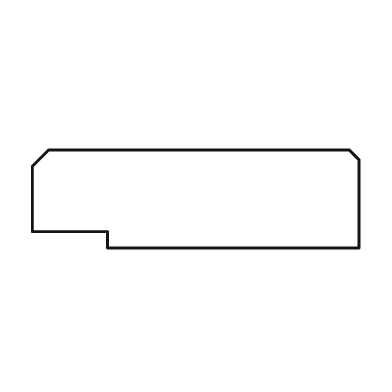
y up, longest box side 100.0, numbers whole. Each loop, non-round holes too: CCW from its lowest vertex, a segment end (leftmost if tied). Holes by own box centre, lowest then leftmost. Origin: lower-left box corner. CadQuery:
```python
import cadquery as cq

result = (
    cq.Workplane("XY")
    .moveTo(23.0, 0.0)
    .lineTo(100.0, 0.0)
    .lineTo(100.0, 27.0)
    .lineTo(97.0, 30.0)
    .lineTo(5.0, 30.0)
    .lineTo(0.0, 25.0)
    .lineTo(0.0, 5.0)
    .lineTo(23.0, 5.0)
    .close()
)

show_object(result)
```